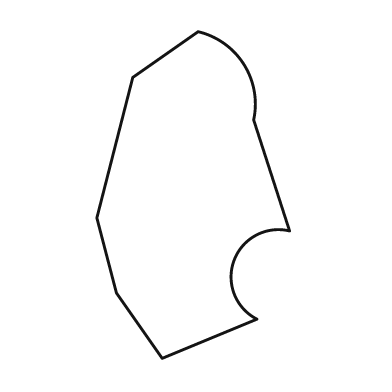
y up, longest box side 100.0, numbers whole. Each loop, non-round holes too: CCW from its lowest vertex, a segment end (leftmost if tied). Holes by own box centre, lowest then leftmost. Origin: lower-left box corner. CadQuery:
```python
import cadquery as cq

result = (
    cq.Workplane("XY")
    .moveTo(20.0, 0.0)
    .lineTo(49.0, 12.0)
    .threePointArc((42.0, 30.0), (59.0, 39.0))
    .lineTo(48.0, 73.0)
    .threePointArc((45.0, 90.0), (31.0, 100.0))
    .lineTo(11.0, 86.0)
    .lineTo(0.0, 43.0)
    .lineTo(6.0, 20.0)
    .close()
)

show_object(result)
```